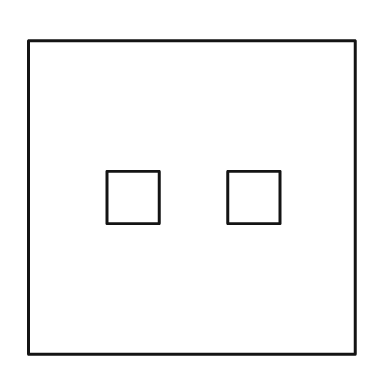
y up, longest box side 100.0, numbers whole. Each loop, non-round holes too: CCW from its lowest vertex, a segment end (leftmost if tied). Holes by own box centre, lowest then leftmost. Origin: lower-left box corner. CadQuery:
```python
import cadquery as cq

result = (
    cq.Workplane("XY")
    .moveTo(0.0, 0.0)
    .lineTo(100.0, 0.0)
    .lineTo(100.0, 96.0)
    .lineTo(0.0, 96.0)
    .close()
    .moveTo(24.0, 40.0)
    .lineTo(40.0, 40.0)
    .lineTo(40.0, 56.0)
    .lineTo(24.0, 56.0)
    .close()
    .moveTo(61.0, 40.0)
    .lineTo(77.0, 40.0)
    .lineTo(77.0, 56.0)
    .lineTo(61.0, 56.0)
    .close()
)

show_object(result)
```